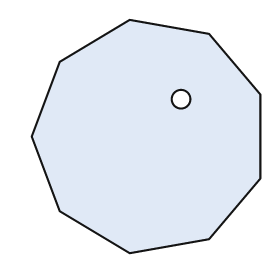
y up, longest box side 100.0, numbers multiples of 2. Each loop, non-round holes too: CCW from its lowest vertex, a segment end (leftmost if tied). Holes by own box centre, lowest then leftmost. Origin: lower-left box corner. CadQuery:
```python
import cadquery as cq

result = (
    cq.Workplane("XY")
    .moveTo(42.0, 0.0)
    .lineTo(76.0, 6.0)
    .lineTo(98.0, 32.0)
    .lineTo(98.0, 68.0)
    .lineTo(76.0, 94.0)
    .lineTo(42.0, 100.0)
    .lineTo(12.0, 82.0)
    .lineTo(0.0, 50.0)
    .lineTo(12.0, 18.0)
    .close()
    .moveTo(64.0, 66.0)
    .circle(4.0)
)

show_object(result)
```